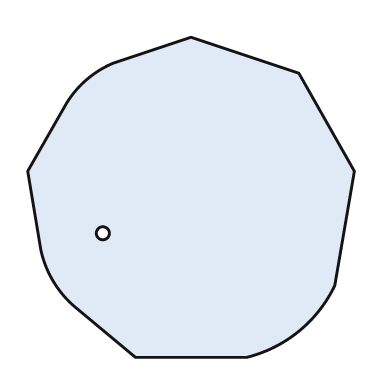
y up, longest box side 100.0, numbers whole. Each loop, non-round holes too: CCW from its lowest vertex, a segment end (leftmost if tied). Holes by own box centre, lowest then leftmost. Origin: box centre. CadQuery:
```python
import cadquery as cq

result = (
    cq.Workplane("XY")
    .moveTo(-17.0, -49.0)
    .lineTo(17.0, -49.0)
    .threePointArc((33.0, -41.0), (44.0, -27.0))
    .lineTo(50.0, 8.0)
    .lineTo(33.0, 38.0)
    .lineTo(0.0, 49.0)
    .lineTo(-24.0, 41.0)
    .threePointArc((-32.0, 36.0), (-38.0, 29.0))
    .lineTo(-50.0, 8.0)
    .lineTo(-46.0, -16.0)
    .threePointArc((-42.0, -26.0), (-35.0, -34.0))
    .close()
    .moveTo(-27.0, -11.0)
    .circle(2.0)
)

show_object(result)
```